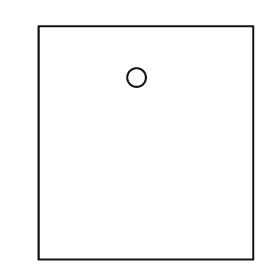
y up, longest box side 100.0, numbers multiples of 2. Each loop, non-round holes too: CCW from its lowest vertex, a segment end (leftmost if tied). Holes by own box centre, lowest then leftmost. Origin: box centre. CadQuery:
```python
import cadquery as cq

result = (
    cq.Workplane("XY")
    .moveTo(-46.0, -50.0)
    .lineTo(46.0, -50.0)
    .lineTo(46.0, 50.0)
    .lineTo(-46.0, 50.0)
    .close()
    .moveTo(-4.0, 28.0)
    .circle(4.0)
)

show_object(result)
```